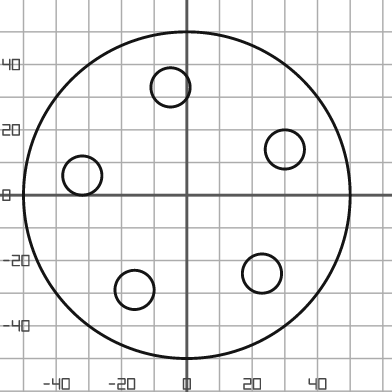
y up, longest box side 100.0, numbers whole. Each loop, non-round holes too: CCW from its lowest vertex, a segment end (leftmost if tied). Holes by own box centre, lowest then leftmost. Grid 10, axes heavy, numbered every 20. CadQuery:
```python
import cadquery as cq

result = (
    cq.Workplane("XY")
    .moveTo(0.0, 0.0)
    .circle(50.0)
    .moveTo(-16.0, -29.0)
    .circle(6.0)
    .moveTo(23.0, -24.0)
    .circle(6.0)
    .moveTo(-32.0, 6.0)
    .circle(6.0)
    .moveTo(30.0, 14.0)
    .circle(6.0)
    .moveTo(-5.0, 33.0)
    .circle(6.0)
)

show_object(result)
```